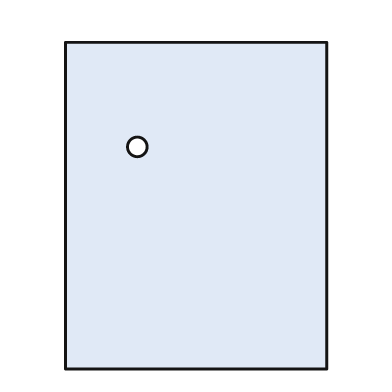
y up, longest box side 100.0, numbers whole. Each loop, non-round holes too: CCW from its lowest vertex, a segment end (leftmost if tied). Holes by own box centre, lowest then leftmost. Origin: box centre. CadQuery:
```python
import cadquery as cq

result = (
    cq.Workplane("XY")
    .moveTo(-40.0, -50.0)
    .lineTo(40.0, -50.0)
    .lineTo(40.0, 50.0)
    .lineTo(-40.0, 50.0)
    .close()
    .moveTo(-18.0, 18.0)
    .circle(3.0)
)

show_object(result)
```